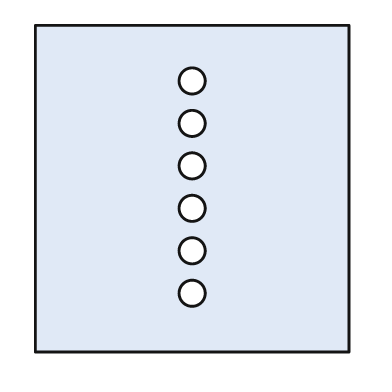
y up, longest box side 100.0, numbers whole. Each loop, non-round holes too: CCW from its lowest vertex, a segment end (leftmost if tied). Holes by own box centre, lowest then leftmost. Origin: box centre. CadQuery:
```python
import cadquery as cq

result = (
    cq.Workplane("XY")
    .moveTo(-48.0, -50.0)
    .lineTo(48.0, -50.0)
    .lineTo(48.0, 50.0)
    .lineTo(-48.0, 50.0)
    .close()
    .moveTo(0.0, -32.0)
    .circle(4.0)
    .moveTo(0.0, -19.0)
    .circle(4.0)
    .moveTo(0.0, -6.0)
    .circle(4.0)
    .moveTo(0.0, 7.0)
    .circle(4.0)
    .moveTo(0.0, 20.0)
    .circle(4.0)
    .moveTo(0.0, 33.0)
    .circle(4.0)
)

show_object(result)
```